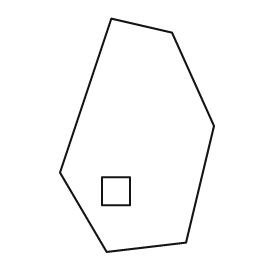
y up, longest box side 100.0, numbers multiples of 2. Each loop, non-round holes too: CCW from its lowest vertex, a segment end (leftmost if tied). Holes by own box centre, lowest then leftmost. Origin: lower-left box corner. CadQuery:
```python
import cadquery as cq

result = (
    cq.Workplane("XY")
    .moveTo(20.0, 0.0)
    .lineTo(54.0, 4.0)
    .lineTo(66.0, 54.0)
    .lineTo(48.0, 94.0)
    .lineTo(22.0, 100.0)
    .lineTo(0.0, 34.0)
    .close()
    .moveTo(18.0, 20.0)
    .lineTo(30.0, 20.0)
    .lineTo(30.0, 32.0)
    .lineTo(18.0, 32.0)
    .close()
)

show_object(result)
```